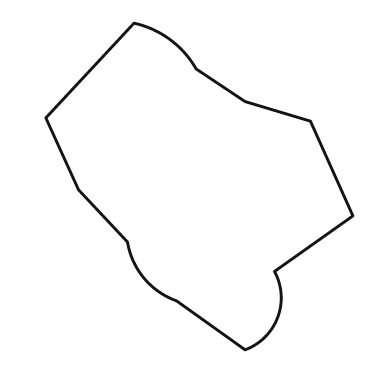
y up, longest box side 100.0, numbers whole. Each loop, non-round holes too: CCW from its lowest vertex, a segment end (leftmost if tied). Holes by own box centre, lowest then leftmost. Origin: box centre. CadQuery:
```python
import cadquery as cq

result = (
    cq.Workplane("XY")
    .moveTo(14.0, -50.0)
    .threePointArc((24.0, -40.0), (23.0, -26.0))
    .lineTo(47.0, -9.0)
    .lineTo(34.0, 20.0)
    .lineTo(14.0, 26.0)
    .lineTo(-1.0, 36.0)
    .threePointArc((-9.0, 45.0), (-20.0, 50.0))
    .lineTo(-47.0, 21.0)
    .lineTo(-37.0, -1.0)
    .lineTo(-22.0, -17.0)
    .threePointArc((-17.0, -28.0), (-7.0, -35.0))
    .close()
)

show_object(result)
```